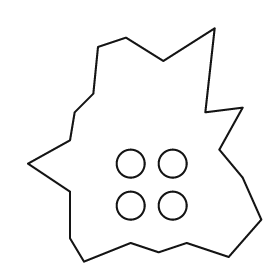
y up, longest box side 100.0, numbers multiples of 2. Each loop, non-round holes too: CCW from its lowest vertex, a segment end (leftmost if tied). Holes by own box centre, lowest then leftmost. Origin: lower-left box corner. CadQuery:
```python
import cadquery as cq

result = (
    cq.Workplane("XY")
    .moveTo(24.0, 0.0)
    .lineTo(44.0, 8.0)
    .lineTo(56.0, 4.0)
    .lineTo(68.0, 8.0)
    .lineTo(86.0, 2.0)
    .lineTo(100.0, 18.0)
    .lineTo(92.0, 36.0)
    .lineTo(82.0, 48.0)
    .lineTo(92.0, 66.0)
    .lineTo(76.0, 64.0)
    .lineTo(80.0, 100.0)
    .lineTo(58.0, 86.0)
    .lineTo(42.0, 96.0)
    .lineTo(30.0, 92.0)
    .lineTo(28.0, 72.0)
    .lineTo(20.0, 64.0)
    .lineTo(18.0, 52.0)
    .lineTo(0.0, 42.0)
    .lineTo(18.0, 30.0)
    .lineTo(18.0, 10.0)
    .close()
    .moveTo(44.0, 24.0)
    .circle(6.0)
    .moveTo(62.0, 24.0)
    .circle(6.0)
    .moveTo(44.0, 42.0)
    .circle(6.0)
    .moveTo(62.0, 42.0)
    .circle(6.0)
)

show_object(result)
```